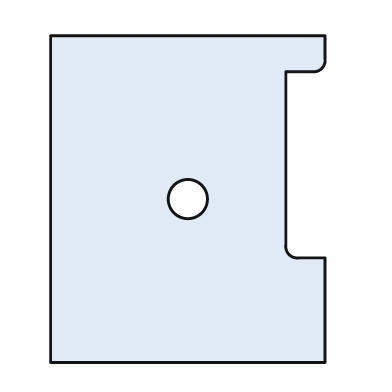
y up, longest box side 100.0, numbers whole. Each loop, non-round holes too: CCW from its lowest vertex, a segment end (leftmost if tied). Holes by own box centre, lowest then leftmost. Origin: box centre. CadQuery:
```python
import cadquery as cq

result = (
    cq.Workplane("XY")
    .moveTo(-42.0, -50.0)
    .lineTo(42.0, -50.0)
    .lineTo(42.0, -18.0)
    .lineTo(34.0, -18.0)
    .threePointArc((31.0, -17.0), (30.0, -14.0))
    .lineTo(30.0, 39.0)
    .lineTo(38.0, 39.0)
    .threePointArc((41.0, 40.0), (42.0, 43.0))
    .lineTo(42.0, 50.0)
    .lineTo(-42.0, 50.0)
    .close()
    .moveTo(0.0, 0.0)
    .circle(6.0)
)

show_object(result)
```